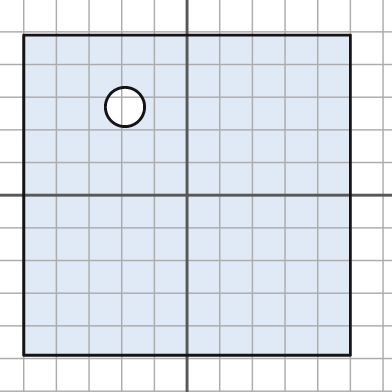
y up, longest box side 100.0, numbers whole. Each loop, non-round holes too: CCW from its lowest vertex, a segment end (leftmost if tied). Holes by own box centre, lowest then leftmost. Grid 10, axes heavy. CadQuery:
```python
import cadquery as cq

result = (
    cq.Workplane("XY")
    .moveTo(-50.0, -49.0)
    .lineTo(50.0, -49.0)
    .lineTo(50.0, 49.0)
    .lineTo(-50.0, 49.0)
    .close()
    .moveTo(-19.0, 27.0)
    .circle(6.0)
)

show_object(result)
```